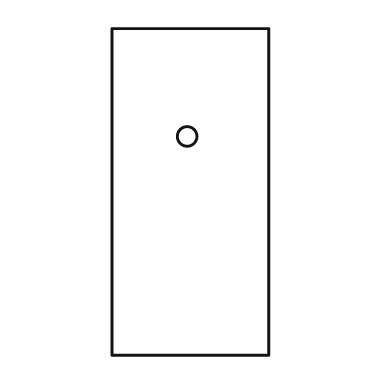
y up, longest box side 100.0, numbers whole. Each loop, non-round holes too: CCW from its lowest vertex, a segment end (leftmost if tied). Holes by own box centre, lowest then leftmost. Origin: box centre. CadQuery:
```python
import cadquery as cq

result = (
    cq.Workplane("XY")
    .moveTo(-24.0, -50.0)
    .lineTo(24.0, -50.0)
    .lineTo(24.0, 50.0)
    .lineTo(-24.0, 50.0)
    .close()
    .moveTo(-1.0, 17.0)
    .circle(3.0)
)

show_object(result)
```